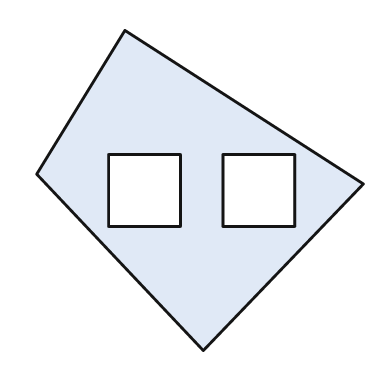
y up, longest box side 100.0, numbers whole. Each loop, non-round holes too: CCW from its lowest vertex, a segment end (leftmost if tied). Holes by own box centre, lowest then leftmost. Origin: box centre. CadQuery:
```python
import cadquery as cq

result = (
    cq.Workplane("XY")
    .moveTo(1.0, -49.0)
    .lineTo(50.0, 2.0)
    .lineTo(-23.0, 49.0)
    .lineTo(-50.0, 5.0)
    .close()
    .moveTo(-28.0, -11.0)
    .lineTo(-6.0, -11.0)
    .lineTo(-6.0, 11.0)
    .lineTo(-28.0, 11.0)
    .close()
    .moveTo(7.0, -11.0)
    .lineTo(29.0, -11.0)
    .lineTo(29.0, 11.0)
    .lineTo(7.0, 11.0)
    .close()
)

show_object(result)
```